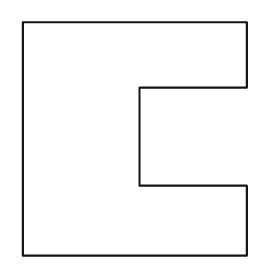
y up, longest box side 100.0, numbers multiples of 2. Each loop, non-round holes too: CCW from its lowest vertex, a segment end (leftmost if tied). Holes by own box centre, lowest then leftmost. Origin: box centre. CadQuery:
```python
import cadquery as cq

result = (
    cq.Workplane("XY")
    .moveTo(-48.0, -50.0)
    .lineTo(48.0, -50.0)
    .lineTo(48.0, -20.0)
    .lineTo(2.0, -20.0)
    .lineTo(2.0, 22.0)
    .lineTo(48.0, 22.0)
    .lineTo(48.0, 50.0)
    .lineTo(-48.0, 50.0)
    .close()
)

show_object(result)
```